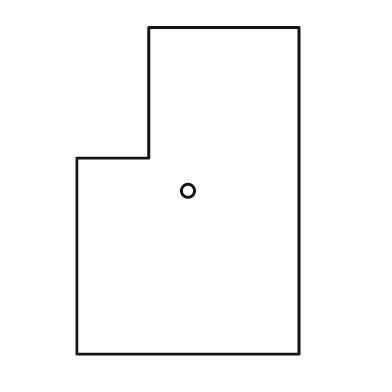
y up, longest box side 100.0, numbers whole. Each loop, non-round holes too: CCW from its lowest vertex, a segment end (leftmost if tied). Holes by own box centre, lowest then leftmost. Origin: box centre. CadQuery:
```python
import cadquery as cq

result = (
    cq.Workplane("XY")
    .moveTo(-34.0, -50.0)
    .lineTo(34.0, -50.0)
    .lineTo(34.0, 50.0)
    .lineTo(-12.0, 50.0)
    .lineTo(-12.0, 10.0)
    .lineTo(-34.0, 10.0)
    .close()
    .moveTo(0.0, 0.0)
    .circle(2.0)
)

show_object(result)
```